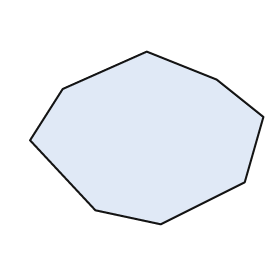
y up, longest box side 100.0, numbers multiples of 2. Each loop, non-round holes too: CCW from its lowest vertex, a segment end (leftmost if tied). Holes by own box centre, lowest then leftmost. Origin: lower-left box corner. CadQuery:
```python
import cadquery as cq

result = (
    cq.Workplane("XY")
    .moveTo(56.0, 0.0)
    .lineTo(92.0, 18.0)
    .lineTo(100.0, 46.0)
    .lineTo(80.0, 62.0)
    .lineTo(50.0, 74.0)
    .lineTo(14.0, 58.0)
    .lineTo(0.0, 36.0)
    .lineTo(28.0, 6.0)
    .close()
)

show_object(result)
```